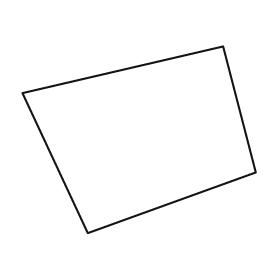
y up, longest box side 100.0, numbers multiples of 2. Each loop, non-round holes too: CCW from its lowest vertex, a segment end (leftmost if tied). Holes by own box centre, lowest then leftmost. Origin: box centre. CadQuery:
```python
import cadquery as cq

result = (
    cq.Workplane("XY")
    .moveTo(-22.0, -40.0)
    .lineTo(50.0, -14.0)
    .lineTo(36.0, 40.0)
    .lineTo(-50.0, 20.0)
    .close()
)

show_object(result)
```